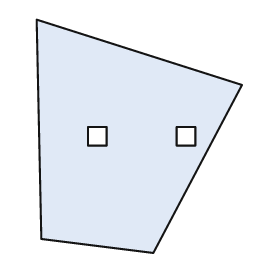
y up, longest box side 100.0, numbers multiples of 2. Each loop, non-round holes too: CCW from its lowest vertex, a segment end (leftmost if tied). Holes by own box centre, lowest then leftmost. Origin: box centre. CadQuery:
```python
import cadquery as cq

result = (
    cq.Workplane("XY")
    .moveTo(6.0, -50.0)
    .lineTo(44.0, 22.0)
    .lineTo(-44.0, 50.0)
    .lineTo(-42.0, -44.0)
    .close()
    .moveTo(-22.0, -4.0)
    .lineTo(-14.0, -4.0)
    .lineTo(-14.0, 4.0)
    .lineTo(-22.0, 4.0)
    .close()
    .moveTo(16.0, -4.0)
    .lineTo(24.0, -4.0)
    .lineTo(24.0, 4.0)
    .lineTo(16.0, 4.0)
    .close()
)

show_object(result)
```